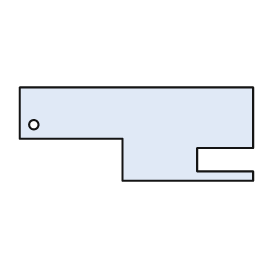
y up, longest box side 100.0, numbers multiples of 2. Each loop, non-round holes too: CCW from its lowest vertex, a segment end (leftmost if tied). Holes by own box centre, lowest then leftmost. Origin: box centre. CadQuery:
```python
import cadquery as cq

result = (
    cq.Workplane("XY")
    .moveTo(-6.0, -20.0)
    .lineTo(50.0, -20.0)
    .lineTo(50.0, -16.0)
    .lineTo(26.0, -16.0)
    .lineTo(26.0, -6.0)
    .lineTo(50.0, -6.0)
    .lineTo(50.0, 20.0)
    .lineTo(-50.0, 20.0)
    .lineTo(-50.0, -2.0)
    .lineTo(-6.0, -2.0)
    .close()
    .moveTo(-44.0, 4.0)
    .circle(2.0)
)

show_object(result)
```